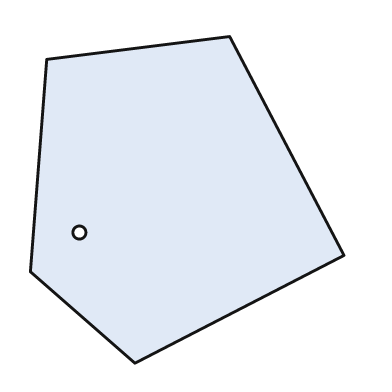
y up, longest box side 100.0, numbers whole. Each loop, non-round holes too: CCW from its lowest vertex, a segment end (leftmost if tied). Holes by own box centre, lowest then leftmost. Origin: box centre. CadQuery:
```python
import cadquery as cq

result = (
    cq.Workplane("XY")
    .moveTo(-16.0, -50.0)
    .lineTo(48.0, -17.0)
    .lineTo(13.0, 50.0)
    .lineTo(-43.0, 43.0)
    .lineTo(-48.0, -22.0)
    .close()
    .moveTo(-33.0, -10.0)
    .circle(2.0)
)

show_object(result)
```